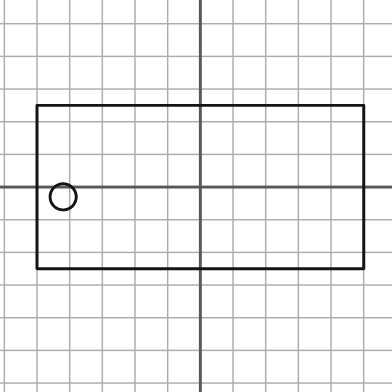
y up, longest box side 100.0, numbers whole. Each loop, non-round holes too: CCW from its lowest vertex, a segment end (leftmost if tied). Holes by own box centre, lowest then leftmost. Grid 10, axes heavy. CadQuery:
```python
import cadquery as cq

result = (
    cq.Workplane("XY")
    .moveTo(-50.0, -25.0)
    .lineTo(50.0, -25.0)
    .lineTo(50.0, 25.0)
    .lineTo(-50.0, 25.0)
    .close()
    .moveTo(-42.0, -3.0)
    .circle(4.0)
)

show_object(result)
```